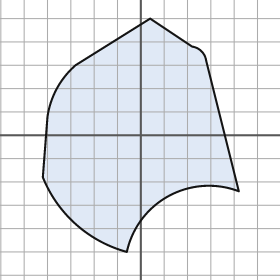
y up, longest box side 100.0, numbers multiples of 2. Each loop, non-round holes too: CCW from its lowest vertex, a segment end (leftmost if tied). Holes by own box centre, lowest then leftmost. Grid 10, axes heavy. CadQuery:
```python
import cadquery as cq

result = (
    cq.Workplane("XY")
    .moveTo(-6.0, -50.0)
    .threePointArc((12.0, -26.0), (42.0, -24.0))
    .lineTo(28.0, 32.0)
    .threePointArc((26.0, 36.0), (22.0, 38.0))
    .lineTo(4.0, 50.0)
    .lineTo(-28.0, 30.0)
    .threePointArc((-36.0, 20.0), (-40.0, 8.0))
    .lineTo(-42.0, -18.0)
    .threePointArc((-28.0, -38.0), (-6.0, -50.0))
    .close()
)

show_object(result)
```